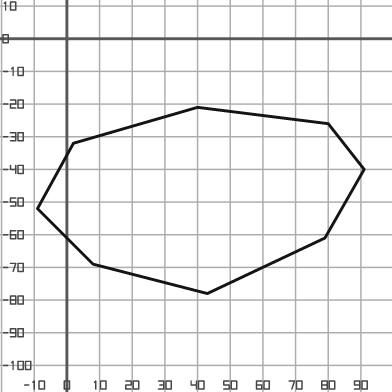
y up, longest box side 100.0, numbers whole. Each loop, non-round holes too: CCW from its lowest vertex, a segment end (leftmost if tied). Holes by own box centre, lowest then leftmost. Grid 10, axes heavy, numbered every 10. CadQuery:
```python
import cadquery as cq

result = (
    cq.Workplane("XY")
    .moveTo(43.0, -78.0)
    .lineTo(79.0, -61.0)
    .lineTo(91.0, -40.0)
    .lineTo(80.0, -26.0)
    .lineTo(40.0, -21.0)
    .lineTo(2.0, -32.0)
    .lineTo(-9.0, -52.0)
    .lineTo(8.0, -69.0)
    .close()
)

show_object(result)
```